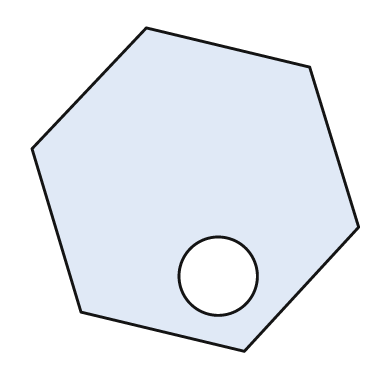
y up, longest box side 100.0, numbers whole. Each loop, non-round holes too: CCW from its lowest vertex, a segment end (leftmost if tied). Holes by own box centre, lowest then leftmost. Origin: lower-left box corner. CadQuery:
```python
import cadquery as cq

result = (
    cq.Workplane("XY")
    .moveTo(65.0, 0.0)
    .lineTo(100.0, 38.0)
    .lineTo(85.0, 87.0)
    .lineTo(35.0, 99.0)
    .lineTo(0.0, 62.0)
    .lineTo(15.0, 12.0)
    .close()
    .moveTo(57.0, 23.0)
    .circle(12.0)
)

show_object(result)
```